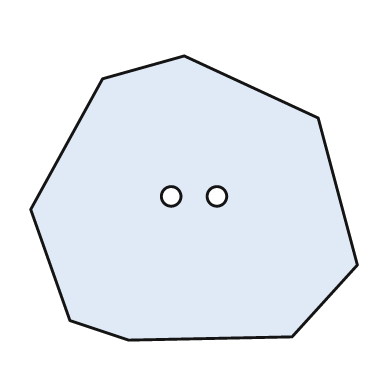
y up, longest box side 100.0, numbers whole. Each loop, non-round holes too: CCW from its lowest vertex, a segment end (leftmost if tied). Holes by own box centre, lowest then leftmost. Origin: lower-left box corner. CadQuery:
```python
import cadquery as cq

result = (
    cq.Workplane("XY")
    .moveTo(30.0, 0.0)
    .lineTo(80.0, 1.0)
    .lineTo(100.0, 23.0)
    .lineTo(88.0, 68.0)
    .lineTo(47.0, 87.0)
    .lineTo(22.0, 80.0)
    .lineTo(0.0, 40.0)
    .lineTo(12.0, 6.0)
    .close()
    .moveTo(43.0, 44.0)
    .circle(3.0)
    .moveTo(57.0, 44.0)
    .circle(3.0)
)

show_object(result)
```